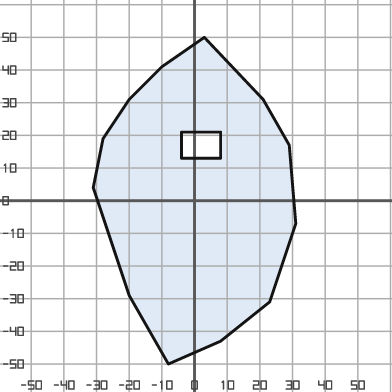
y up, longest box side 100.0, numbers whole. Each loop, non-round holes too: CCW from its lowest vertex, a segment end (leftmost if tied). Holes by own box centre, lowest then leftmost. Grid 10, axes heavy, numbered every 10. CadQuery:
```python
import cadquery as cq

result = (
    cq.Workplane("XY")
    .moveTo(-8.0, -50.0)
    .lineTo(8.0, -43.0)
    .lineTo(23.0, -31.0)
    .lineTo(31.0, -7.0)
    .lineTo(29.0, 17.0)
    .lineTo(21.0, 31.0)
    .lineTo(3.0, 50.0)
    .lineTo(-10.0, 41.0)
    .lineTo(-20.0, 31.0)
    .lineTo(-28.0, 19.0)
    .lineTo(-31.0, 4.0)
    .lineTo(-20.0, -29.0)
    .close()
    .moveTo(-4.0, 13.0)
    .lineTo(8.0, 13.0)
    .lineTo(8.0, 21.0)
    .lineTo(-4.0, 21.0)
    .close()
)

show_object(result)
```